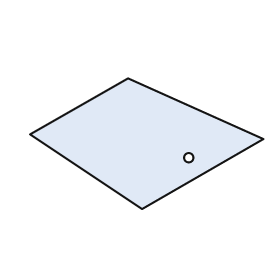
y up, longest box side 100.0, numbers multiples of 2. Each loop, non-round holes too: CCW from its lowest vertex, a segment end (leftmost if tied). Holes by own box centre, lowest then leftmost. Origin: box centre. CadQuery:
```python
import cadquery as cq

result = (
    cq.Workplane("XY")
    .moveTo(-2.0, -28.0)
    .lineTo(50.0, 2.0)
    .lineTo(-8.0, 28.0)
    .lineTo(-50.0, 4.0)
    .close()
    .moveTo(18.0, -6.0)
    .circle(2.0)
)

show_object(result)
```